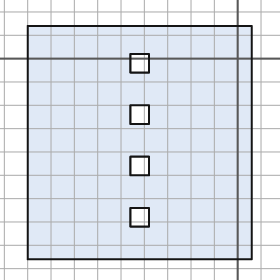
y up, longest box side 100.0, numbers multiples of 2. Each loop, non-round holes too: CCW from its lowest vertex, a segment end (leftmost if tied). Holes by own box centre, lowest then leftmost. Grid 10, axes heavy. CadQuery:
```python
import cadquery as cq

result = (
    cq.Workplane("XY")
    .moveTo(-90.0, -86.0)
    .lineTo(6.0, -86.0)
    .lineTo(6.0, 14.0)
    .lineTo(-90.0, 14.0)
    .close()
    .moveTo(-46.0, -72.0)
    .lineTo(-38.0, -72.0)
    .lineTo(-38.0, -64.0)
    .lineTo(-46.0, -64.0)
    .close()
    .moveTo(-46.0, -50.0)
    .lineTo(-38.0, -50.0)
    .lineTo(-38.0, -42.0)
    .lineTo(-46.0, -42.0)
    .close()
    .moveTo(-46.0, -28.0)
    .lineTo(-38.0, -28.0)
    .lineTo(-38.0, -20.0)
    .lineTo(-46.0, -20.0)
    .close()
    .moveTo(-46.0, -6.0)
    .lineTo(-38.0, -6.0)
    .lineTo(-38.0, 2.0)
    .lineTo(-46.0, 2.0)
    .close()
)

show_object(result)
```